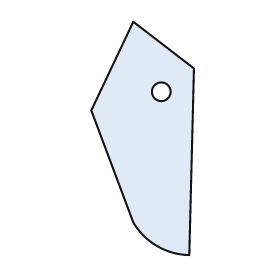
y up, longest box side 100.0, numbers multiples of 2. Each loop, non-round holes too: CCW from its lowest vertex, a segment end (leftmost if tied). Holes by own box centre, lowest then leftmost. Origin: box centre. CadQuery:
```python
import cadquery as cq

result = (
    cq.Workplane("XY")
    .moveTo(20.0, -50.0)
    .lineTo(22.0, 30.0)
    .lineTo(-4.0, 50.0)
    .lineTo(-22.0, 12.0)
    .lineTo(-4.0, -36.0)
    .threePointArc((6.0, -46.0), (20.0, -50.0))
    .close()
    .moveTo(8.0, 20.0)
    .circle(4.0)
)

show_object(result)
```